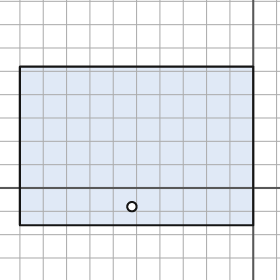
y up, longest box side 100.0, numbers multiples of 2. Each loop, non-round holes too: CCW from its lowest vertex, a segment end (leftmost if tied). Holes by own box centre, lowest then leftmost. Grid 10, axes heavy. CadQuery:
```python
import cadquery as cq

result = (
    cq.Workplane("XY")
    .moveTo(-100.0, -16.0)
    .lineTo(0.0, -16.0)
    .lineTo(0.0, 52.0)
    .lineTo(-100.0, 52.0)
    .close()
    .moveTo(-52.0, -8.0)
    .circle(2.0)
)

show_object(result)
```